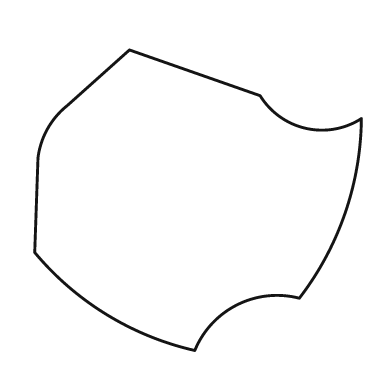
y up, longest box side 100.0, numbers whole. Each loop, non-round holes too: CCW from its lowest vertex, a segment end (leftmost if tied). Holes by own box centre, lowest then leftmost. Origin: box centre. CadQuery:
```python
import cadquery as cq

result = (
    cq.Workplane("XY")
    .moveTo(-1.0, -46.0)
    .threePointArc((12.0, -32.0), (31.0, -30.0))
    .threePointArc((45.0, -4.0), (50.0, 25.0))
    .threePointArc((33.0, 22.0), (19.0, 32.0))
    .lineTo(-21.0, 46.0)
    .lineTo(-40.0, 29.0)
    .threePointArc((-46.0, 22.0), (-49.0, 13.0))
    .lineTo(-50.0, -16.0)
    .threePointArc((-28.0, -35.0), (-1.0, -46.0))
    .close()
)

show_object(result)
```